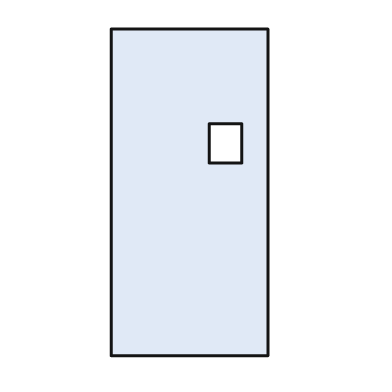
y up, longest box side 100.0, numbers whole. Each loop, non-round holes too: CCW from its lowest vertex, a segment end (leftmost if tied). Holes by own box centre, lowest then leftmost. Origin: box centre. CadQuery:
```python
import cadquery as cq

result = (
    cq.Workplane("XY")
    .moveTo(-24.0, -50.0)
    .lineTo(24.0, -50.0)
    .lineTo(24.0, 50.0)
    .lineTo(-24.0, 50.0)
    .close()
    .moveTo(6.0, 9.0)
    .lineTo(16.0, 9.0)
    .lineTo(16.0, 21.0)
    .lineTo(6.0, 21.0)
    .close()
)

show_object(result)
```